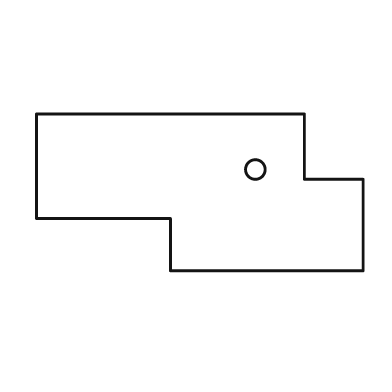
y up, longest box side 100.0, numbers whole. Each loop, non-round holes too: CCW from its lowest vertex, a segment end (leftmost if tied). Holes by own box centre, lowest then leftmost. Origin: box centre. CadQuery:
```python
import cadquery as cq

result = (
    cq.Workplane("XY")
    .moveTo(-9.0, -24.0)
    .lineTo(50.0, -24.0)
    .lineTo(50.0, 4.0)
    .lineTo(32.0, 4.0)
    .lineTo(32.0, 24.0)
    .lineTo(-50.0, 24.0)
    .lineTo(-50.0, -8.0)
    .lineTo(-9.0, -8.0)
    .close()
    .moveTo(17.0, 7.0)
    .circle(3.0)
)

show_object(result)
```